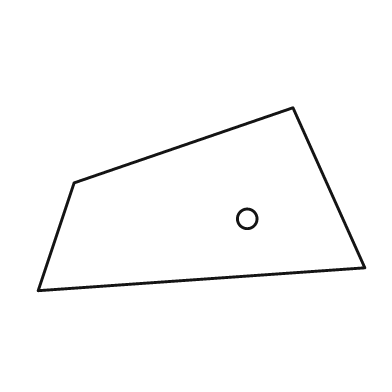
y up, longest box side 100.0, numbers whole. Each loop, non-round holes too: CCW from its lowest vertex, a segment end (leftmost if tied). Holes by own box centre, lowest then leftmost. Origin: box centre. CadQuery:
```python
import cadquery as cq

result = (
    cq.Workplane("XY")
    .moveTo(-50.0, -28.0)
    .lineTo(50.0, -21.0)
    .lineTo(28.0, 28.0)
    .lineTo(-39.0, 5.0)
    .close()
    .moveTo(14.0, -6.0)
    .circle(3.0)
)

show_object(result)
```